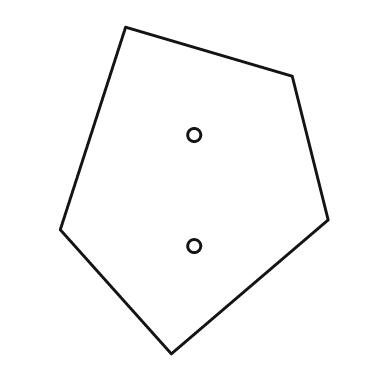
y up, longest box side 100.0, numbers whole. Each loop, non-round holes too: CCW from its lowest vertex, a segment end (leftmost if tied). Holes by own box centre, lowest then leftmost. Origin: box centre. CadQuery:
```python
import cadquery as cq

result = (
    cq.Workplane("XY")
    .moveTo(-7.0, -50.0)
    .lineTo(41.0, -9.0)
    .lineTo(30.0, 35.0)
    .lineTo(-21.0, 50.0)
    .lineTo(-41.0, -12.0)
    .close()
    .moveTo(0.0, -17.0)
    .circle(2.0)
    .moveTo(0.0, 17.0)
    .circle(2.0)
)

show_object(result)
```